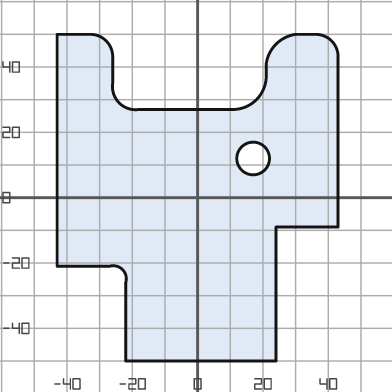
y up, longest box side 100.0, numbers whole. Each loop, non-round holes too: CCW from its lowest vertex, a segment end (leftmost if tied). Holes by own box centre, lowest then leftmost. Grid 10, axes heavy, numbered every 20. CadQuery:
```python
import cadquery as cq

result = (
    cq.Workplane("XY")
    .moveTo(-22.0, -50.0)
    .lineTo(24.0, -50.0)
    .lineTo(24.0, -9.0)
    .lineTo(43.0, -9.0)
    .lineTo(43.0, 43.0)
    .threePointArc((41.0, 48.0), (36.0, 50.0))
    .lineTo(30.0, 50.0)
    .threePointArc((24.0, 47.0), (21.0, 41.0))
    .lineTo(21.0, 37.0)
    .threePointArc((18.0, 30.0), (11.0, 27.0))
    .lineTo(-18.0, 27.0)
    .threePointArc((-24.0, 29.0), (-26.0, 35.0))
    .lineTo(-26.0, 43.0)
    .threePointArc((-28.0, 48.0), (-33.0, 50.0))
    .lineTo(-43.0, 50.0)
    .lineTo(-43.0, -21.0)
    .lineTo(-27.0, -21.0)
    .threePointArc((-23.0, -22.0), (-22.0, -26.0))
    .close()
    .moveTo(17.0, 12.0)
    .circle(5.0)
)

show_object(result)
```